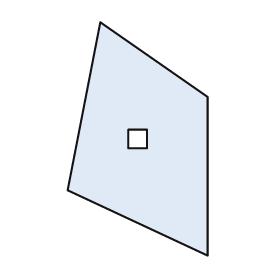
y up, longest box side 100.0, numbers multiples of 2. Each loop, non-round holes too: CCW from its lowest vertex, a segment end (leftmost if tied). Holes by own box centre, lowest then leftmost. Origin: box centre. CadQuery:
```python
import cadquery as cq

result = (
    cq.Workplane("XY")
    .moveTo(30.0, -50.0)
    .lineTo(30.0, 18.0)
    .lineTo(-16.0, 50.0)
    .lineTo(-30.0, -22.0)
    .close()
    .moveTo(-4.0, -4.0)
    .lineTo(4.0, -4.0)
    .lineTo(4.0, 4.0)
    .lineTo(-4.0, 4.0)
    .close()
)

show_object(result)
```